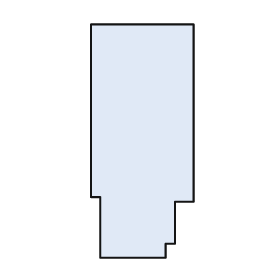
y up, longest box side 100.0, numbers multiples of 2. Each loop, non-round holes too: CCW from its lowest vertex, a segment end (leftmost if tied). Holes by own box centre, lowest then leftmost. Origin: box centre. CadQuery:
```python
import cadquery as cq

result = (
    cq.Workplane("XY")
    .moveTo(-18.0, -50.0)
    .lineTo(10.0, -50.0)
    .lineTo(10.0, -44.0)
    .lineTo(14.0, -44.0)
    .lineTo(14.0, -26.0)
    .lineTo(22.0, -26.0)
    .lineTo(22.0, 50.0)
    .lineTo(-22.0, 50.0)
    .lineTo(-22.0, -24.0)
    .lineTo(-18.0, -24.0)
    .close()
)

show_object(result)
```